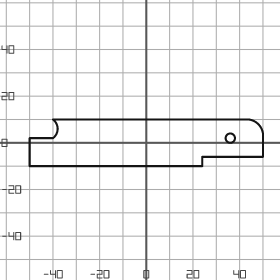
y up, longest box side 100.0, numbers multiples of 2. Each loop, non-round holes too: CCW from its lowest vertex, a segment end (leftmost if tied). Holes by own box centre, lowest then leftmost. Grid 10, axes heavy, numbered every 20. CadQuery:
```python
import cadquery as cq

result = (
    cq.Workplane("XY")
    .moveTo(-50.0, -10.0)
    .lineTo(24.0, -10.0)
    .lineTo(24.0, -6.0)
    .lineTo(50.0, -6.0)
    .lineTo(50.0, 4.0)
    .threePointArc((48.0, 8.0), (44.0, 10.0))
    .lineTo(-40.0, 10.0)
    .threePointArc((-38.0, 6.0), (-40.0, 2.0))
    .lineTo(-50.0, 2.0)
    .close()
    .moveTo(36.0, 2.0)
    .circle(2.0)
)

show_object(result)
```